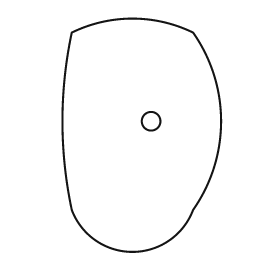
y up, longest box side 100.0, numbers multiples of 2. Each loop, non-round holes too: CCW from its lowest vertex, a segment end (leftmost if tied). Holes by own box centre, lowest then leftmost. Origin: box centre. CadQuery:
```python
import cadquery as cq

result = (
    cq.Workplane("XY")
    .moveTo(-30.0, -32.0)
    .threePointArc((-4.0, -50.0), (22.0, -32.0))
    .threePointArc((34.0, 6.0), (22.0, 44.0))
    .threePointArc((-4.0, 50.0), (-30.0, 44.0))
    .threePointArc((-34.0, 6.0), (-30.0, -32.0))
    .close()
    .moveTo(4.0, 6.0)
    .circle(4.0)
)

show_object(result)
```